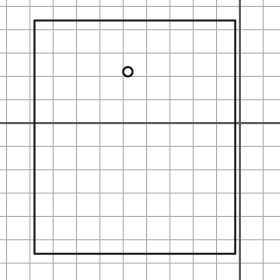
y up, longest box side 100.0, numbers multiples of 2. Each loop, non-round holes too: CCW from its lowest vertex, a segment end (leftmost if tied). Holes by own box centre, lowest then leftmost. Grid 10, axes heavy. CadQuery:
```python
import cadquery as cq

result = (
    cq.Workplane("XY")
    .moveTo(-88.0, -56.0)
    .lineTo(-2.0, -56.0)
    .lineTo(-2.0, 44.0)
    .lineTo(-88.0, 44.0)
    .close()
    .moveTo(-48.0, 22.0)
    .circle(2.0)
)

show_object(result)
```